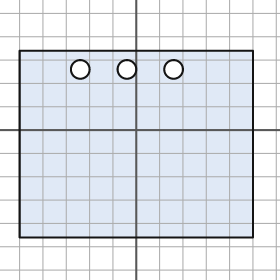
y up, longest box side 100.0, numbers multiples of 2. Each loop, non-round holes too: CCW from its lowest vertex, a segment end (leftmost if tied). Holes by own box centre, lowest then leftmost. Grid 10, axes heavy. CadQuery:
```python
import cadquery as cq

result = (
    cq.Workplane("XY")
    .moveTo(-50.0, -46.0)
    .lineTo(50.0, -46.0)
    .lineTo(50.0, 34.0)
    .lineTo(-50.0, 34.0)
    .close()
    .moveTo(-24.0, 26.0)
    .circle(4.0)
    .moveTo(-4.0, 26.0)
    .circle(4.0)
    .moveTo(16.0, 26.0)
    .circle(4.0)
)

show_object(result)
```